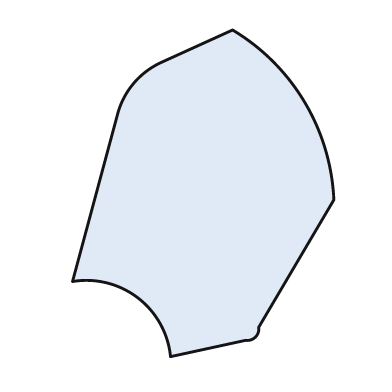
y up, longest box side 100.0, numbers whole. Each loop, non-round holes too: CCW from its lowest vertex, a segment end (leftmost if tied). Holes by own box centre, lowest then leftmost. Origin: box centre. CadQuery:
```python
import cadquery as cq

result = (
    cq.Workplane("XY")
    .moveTo(-10.0, -50.0)
    .lineTo(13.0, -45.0)
    .threePointArc((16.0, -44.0), (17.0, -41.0))
    .lineTo(40.0, -2.0)
    .threePointArc((31.0, 28.0), (9.0, 50.0))
    .lineTo(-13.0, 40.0)
    .threePointArc((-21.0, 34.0), (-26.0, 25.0))
    .lineTo(-40.0, -27.0)
    .threePointArc((-20.0, -32.0), (-10.0, -50.0))
    .close()
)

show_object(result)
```